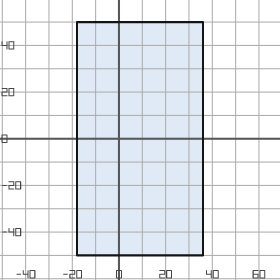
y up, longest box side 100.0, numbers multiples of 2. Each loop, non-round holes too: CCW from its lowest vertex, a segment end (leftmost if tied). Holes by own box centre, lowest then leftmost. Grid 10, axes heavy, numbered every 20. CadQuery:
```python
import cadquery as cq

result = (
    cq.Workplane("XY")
    .moveTo(-18.0, -50.0)
    .lineTo(36.0, -50.0)
    .lineTo(36.0, 50.0)
    .lineTo(-18.0, 50.0)
    .close()
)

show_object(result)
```